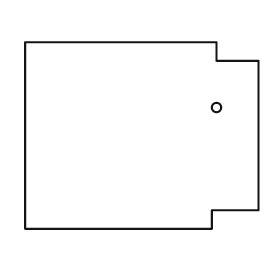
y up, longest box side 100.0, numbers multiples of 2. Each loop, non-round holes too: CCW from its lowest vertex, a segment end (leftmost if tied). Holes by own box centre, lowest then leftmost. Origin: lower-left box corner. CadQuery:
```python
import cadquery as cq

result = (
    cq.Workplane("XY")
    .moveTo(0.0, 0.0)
    .lineTo(80.0, 0.0)
    .lineTo(80.0, 8.0)
    .lineTo(100.0, 8.0)
    .lineTo(100.0, 72.0)
    .lineTo(82.0, 72.0)
    .lineTo(82.0, 80.0)
    .lineTo(0.0, 80.0)
    .close()
    .moveTo(82.0, 52.0)
    .circle(2.0)
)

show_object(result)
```